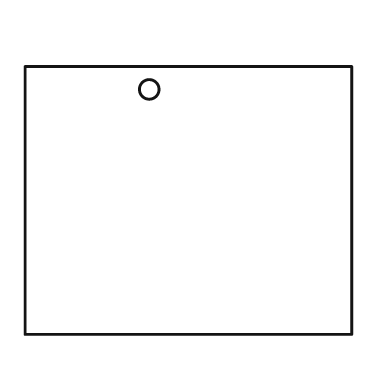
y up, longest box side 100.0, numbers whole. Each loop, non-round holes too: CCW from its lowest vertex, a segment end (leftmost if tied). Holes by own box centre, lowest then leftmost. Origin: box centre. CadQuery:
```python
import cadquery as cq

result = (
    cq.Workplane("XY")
    .moveTo(-50.0, -41.0)
    .lineTo(50.0, -41.0)
    .lineTo(50.0, 41.0)
    .lineTo(-50.0, 41.0)
    .close()
    .moveTo(-12.0, 34.0)
    .circle(3.0)
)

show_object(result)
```